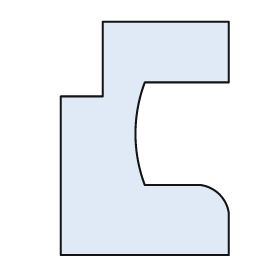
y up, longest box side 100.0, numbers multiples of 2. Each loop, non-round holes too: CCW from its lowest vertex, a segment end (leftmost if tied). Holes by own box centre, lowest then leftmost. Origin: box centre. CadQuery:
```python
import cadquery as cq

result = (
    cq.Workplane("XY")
    .moveTo(-36.0, -50.0)
    .lineTo(36.0, -50.0)
    .lineTo(36.0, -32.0)
    .threePointArc((32.0, -24.0), (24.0, -20.0))
    .lineTo(0.0, -20.0)
    .threePointArc((-4.0, 2.0), (0.0, 24.0))
    .lineTo(36.0, 24.0)
    .lineTo(36.0, 50.0)
    .lineTo(-18.0, 50.0)
    .lineTo(-18.0, 18.0)
    .lineTo(-36.0, 18.0)
    .close()
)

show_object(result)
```